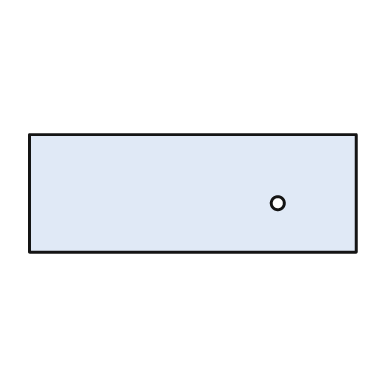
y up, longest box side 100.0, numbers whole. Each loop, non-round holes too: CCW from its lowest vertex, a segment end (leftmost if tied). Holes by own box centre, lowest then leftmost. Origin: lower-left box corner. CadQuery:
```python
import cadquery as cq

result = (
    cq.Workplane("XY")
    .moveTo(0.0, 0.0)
    .lineTo(100.0, 0.0)
    .lineTo(100.0, 36.0)
    .lineTo(0.0, 36.0)
    .close()
    .moveTo(76.0, 15.0)
    .circle(2.0)
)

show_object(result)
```